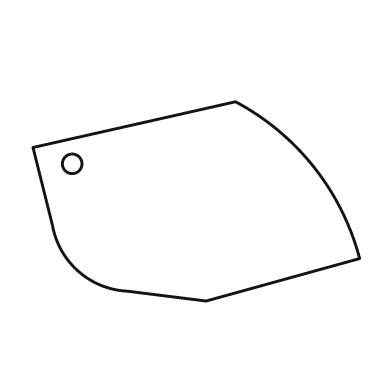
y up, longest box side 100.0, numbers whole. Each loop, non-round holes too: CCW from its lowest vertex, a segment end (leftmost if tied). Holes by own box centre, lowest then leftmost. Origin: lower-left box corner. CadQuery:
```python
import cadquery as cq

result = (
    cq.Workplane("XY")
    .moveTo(53.0, 0.0)
    .lineTo(100.0, 13.0)
    .threePointArc((86.0, 41.0), (62.0, 61.0))
    .lineTo(0.0, 47.0)
    .lineTo(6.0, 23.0)
    .threePointArc((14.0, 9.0), (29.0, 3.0))
    .close()
    .moveTo(12.0, 42.0)
    .circle(3.0)
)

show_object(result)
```